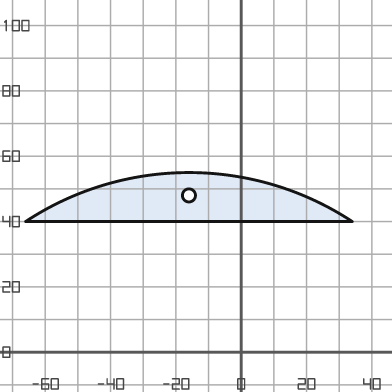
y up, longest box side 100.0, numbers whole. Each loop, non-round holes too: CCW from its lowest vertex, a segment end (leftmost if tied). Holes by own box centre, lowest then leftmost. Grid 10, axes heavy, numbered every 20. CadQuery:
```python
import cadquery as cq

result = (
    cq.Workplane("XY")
    .moveTo(-66.0, 40.0)
    .lineTo(34.0, 40.0)
    .threePointArc((-16.0, 55.0), (-66.0, 40.0))
    .close()
    .moveTo(-16.0, 48.0)
    .circle(2.0)
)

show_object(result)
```